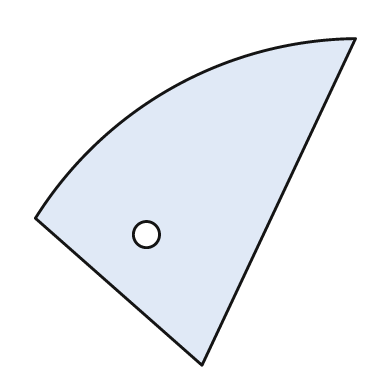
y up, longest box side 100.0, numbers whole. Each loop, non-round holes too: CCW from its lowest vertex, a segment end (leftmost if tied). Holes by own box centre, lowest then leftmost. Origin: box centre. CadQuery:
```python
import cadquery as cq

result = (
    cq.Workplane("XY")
    .moveTo(2.0, -50.0)
    .lineTo(49.0, 50.0)
    .threePointArc((-7.0, 35.0), (-49.0, -5.0))
    .close()
    .moveTo(-15.0, -10.0)
    .circle(4.0)
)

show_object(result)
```